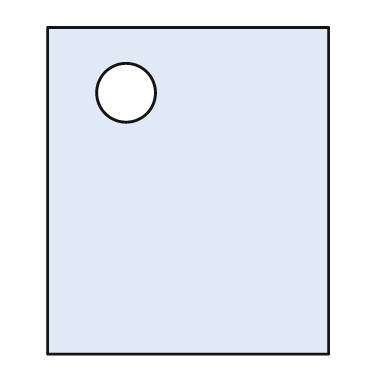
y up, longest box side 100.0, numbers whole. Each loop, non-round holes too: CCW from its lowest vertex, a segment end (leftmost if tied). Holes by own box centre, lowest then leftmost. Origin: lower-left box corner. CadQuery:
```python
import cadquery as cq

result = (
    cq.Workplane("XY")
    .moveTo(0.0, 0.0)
    .lineTo(86.0, 0.0)
    .lineTo(86.0, 100.0)
    .lineTo(0.0, 100.0)
    .close()
    .moveTo(24.0, 80.0)
    .circle(9.0)
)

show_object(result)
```